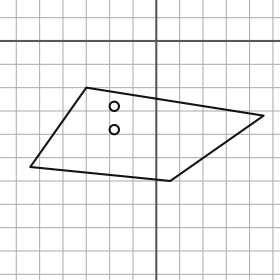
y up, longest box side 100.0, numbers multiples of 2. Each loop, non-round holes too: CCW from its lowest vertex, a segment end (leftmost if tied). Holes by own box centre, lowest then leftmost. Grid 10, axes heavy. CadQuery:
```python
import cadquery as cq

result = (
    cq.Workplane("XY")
    .moveTo(6.0, -60.0)
    .lineTo(46.0, -32.0)
    .lineTo(-30.0, -20.0)
    .lineTo(-54.0, -54.0)
    .close()
    .moveTo(-18.0, -38.0)
    .circle(2.0)
    .moveTo(-18.0, -28.0)
    .circle(2.0)
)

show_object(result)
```